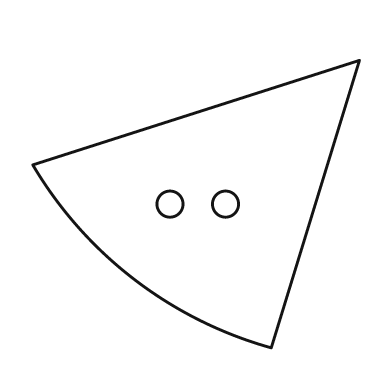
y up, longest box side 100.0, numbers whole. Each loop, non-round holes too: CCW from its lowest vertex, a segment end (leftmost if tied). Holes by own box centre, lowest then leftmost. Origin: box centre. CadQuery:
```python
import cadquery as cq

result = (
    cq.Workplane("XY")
    .moveTo(23.0, -44.0)
    .lineTo(50.0, 44.0)
    .lineTo(-50.0, 12.0)
    .threePointArc((-19.0, -23.0), (23.0, -44.0))
    .close()
    .moveTo(-8.0, 0.0)
    .circle(4.0)
    .moveTo(9.0, 0.0)
    .circle(4.0)
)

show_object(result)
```